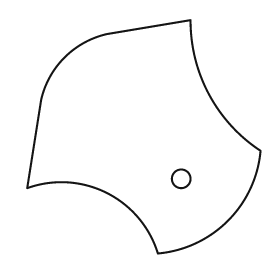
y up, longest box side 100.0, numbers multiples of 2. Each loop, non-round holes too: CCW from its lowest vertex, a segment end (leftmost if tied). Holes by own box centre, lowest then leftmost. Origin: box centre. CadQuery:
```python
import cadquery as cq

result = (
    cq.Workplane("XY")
    .moveTo(6.0, -50.0)
    .threePointArc((36.0, -36.0), (50.0, -6.0))
    .threePointArc((28.0, 18.0), (20.0, 50.0))
    .lineTo(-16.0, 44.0)
    .threePointArc((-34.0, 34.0), (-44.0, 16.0))
    .lineTo(-50.0, -22.0)
    .threePointArc((-16.0, -24.0), (6.0, -50.0))
    .close()
    .moveTo(16.0, -18.0)
    .circle(4.0)
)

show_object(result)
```